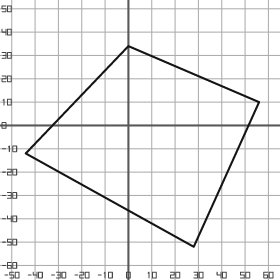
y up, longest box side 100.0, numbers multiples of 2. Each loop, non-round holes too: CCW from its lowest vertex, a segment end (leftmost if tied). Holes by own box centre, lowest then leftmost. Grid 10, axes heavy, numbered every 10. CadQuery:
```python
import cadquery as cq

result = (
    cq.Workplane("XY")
    .moveTo(28.0, -52.0)
    .lineTo(56.0, 10.0)
    .lineTo(0.0, 34.0)
    .lineTo(-44.0, -12.0)
    .close()
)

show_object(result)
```